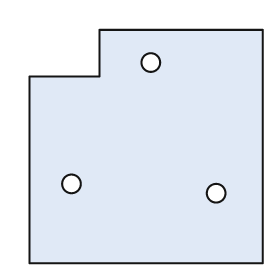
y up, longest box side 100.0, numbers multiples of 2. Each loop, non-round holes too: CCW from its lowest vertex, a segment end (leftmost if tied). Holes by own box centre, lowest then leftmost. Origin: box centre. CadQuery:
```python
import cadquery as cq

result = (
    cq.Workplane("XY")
    .moveTo(-50.0, -50.0)
    .lineTo(50.0, -50.0)
    .lineTo(50.0, 50.0)
    .lineTo(-20.0, 50.0)
    .lineTo(-20.0, 30.0)
    .lineTo(-50.0, 30.0)
    .close()
    .moveTo(30.0, -20.0)
    .circle(4.0)
    .moveTo(-32.0, -16.0)
    .circle(4.0)
    .moveTo(2.0, 36.0)
    .circle(4.0)
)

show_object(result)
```